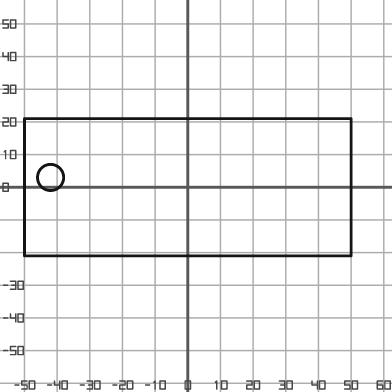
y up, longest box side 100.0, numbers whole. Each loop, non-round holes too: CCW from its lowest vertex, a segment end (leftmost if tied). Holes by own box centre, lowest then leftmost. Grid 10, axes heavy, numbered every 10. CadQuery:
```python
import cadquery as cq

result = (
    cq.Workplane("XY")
    .moveTo(-50.0, -21.0)
    .lineTo(50.0, -21.0)
    .lineTo(50.0, 21.0)
    .lineTo(-50.0, 21.0)
    .close()
    .moveTo(-42.0, 3.0)
    .circle(4.0)
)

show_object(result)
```